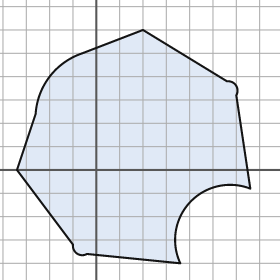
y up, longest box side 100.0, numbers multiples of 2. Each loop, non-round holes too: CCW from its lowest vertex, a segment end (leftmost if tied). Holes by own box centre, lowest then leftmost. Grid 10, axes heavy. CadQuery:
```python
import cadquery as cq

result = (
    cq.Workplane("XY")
    .moveTo(36.0, -40.0)
    .threePointArc((40.0, -14.0), (66.0, -8.0))
    .lineTo(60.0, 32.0)
    .threePointArc((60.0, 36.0), (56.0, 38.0))
    .lineTo(20.0, 60.0)
    .lineTo(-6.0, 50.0)
    .threePointArc((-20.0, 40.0), (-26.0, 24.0))
    .lineTo(-34.0, 0.0)
    .lineTo(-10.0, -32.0)
    .threePointArc((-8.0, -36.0), (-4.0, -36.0))
    .close()
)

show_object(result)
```